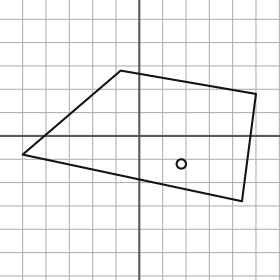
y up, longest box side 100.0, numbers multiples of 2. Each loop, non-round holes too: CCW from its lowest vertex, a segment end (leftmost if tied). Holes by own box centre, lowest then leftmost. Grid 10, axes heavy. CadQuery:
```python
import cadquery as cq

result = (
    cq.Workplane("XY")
    .moveTo(44.0, -28.0)
    .lineTo(50.0, 18.0)
    .lineTo(-8.0, 28.0)
    .lineTo(-50.0, -8.0)
    .close()
    .moveTo(18.0, -12.0)
    .circle(2.0)
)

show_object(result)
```